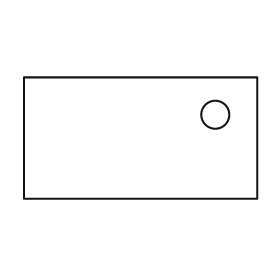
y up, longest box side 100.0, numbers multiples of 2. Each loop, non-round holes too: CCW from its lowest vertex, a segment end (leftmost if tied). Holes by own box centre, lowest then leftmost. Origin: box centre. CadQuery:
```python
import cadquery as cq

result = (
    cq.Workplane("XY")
    .moveTo(-50.0, -26.0)
    .lineTo(50.0, -26.0)
    .lineTo(50.0, 26.0)
    .lineTo(-50.0, 26.0)
    .close()
    .moveTo(32.0, 10.0)
    .circle(6.0)
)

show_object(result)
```